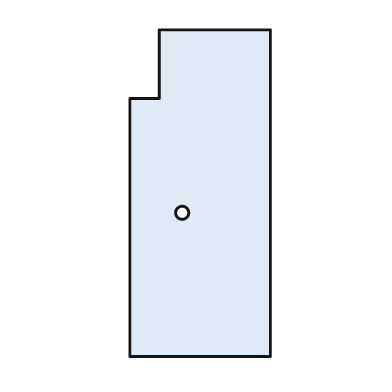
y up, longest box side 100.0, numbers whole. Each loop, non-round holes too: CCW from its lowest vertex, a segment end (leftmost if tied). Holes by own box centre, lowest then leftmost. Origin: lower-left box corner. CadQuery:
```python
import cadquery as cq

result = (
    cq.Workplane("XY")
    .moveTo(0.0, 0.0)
    .lineTo(43.0, 0.0)
    .lineTo(43.0, 100.0)
    .lineTo(9.0, 100.0)
    .lineTo(9.0, 79.0)
    .lineTo(0.0, 79.0)
    .close()
    .moveTo(16.0, 44.0)
    .circle(2.0)
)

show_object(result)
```